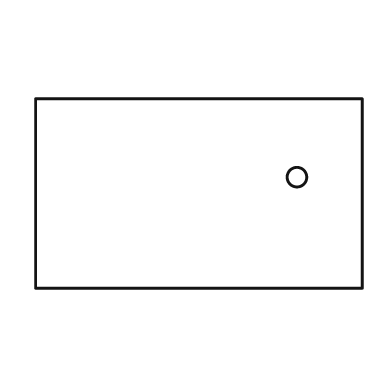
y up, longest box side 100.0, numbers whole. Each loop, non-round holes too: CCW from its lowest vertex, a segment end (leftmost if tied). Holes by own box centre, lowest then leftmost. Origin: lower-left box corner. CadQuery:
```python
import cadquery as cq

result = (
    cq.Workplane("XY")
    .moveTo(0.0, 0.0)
    .lineTo(100.0, 0.0)
    .lineTo(100.0, 58.0)
    .lineTo(0.0, 58.0)
    .close()
    .moveTo(80.0, 34.0)
    .circle(3.0)
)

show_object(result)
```